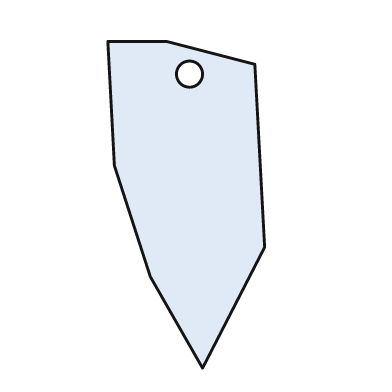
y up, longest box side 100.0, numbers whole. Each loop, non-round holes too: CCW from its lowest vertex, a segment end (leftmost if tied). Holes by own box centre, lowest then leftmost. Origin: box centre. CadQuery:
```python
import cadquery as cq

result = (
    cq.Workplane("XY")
    .moveTo(5.0, -50.0)
    .lineTo(24.0, -13.0)
    .lineTo(21.0, 43.0)
    .lineTo(-6.0, 50.0)
    .lineTo(-24.0, 50.0)
    .lineTo(-22.0, 12.0)
    .lineTo(-11.0, -22.0)
    .close()
    .moveTo(1.0, 40.0)
    .circle(4.0)
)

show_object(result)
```